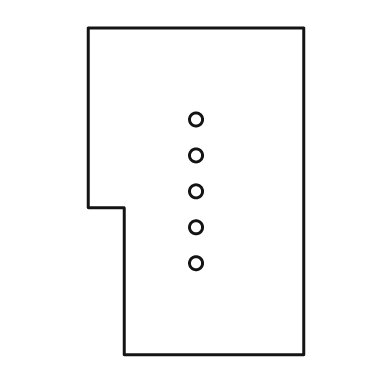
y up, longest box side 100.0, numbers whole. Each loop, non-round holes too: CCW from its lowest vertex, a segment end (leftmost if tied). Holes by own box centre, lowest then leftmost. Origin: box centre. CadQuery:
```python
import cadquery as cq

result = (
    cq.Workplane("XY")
    .moveTo(-22.0, -50.0)
    .lineTo(33.0, -50.0)
    .lineTo(33.0, 50.0)
    .lineTo(-33.0, 50.0)
    .lineTo(-33.0, -5.0)
    .lineTo(-22.0, -5.0)
    .close()
    .moveTo(0.0, -22.0)
    .circle(2.0)
    .moveTo(0.0, -11.0)
    .circle(2.0)
    .moveTo(0.0, 0.0)
    .circle(2.0)
    .moveTo(0.0, 11.0)
    .circle(2.0)
    .moveTo(0.0, 22.0)
    .circle(2.0)
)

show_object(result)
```